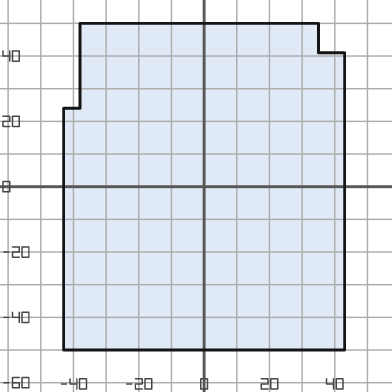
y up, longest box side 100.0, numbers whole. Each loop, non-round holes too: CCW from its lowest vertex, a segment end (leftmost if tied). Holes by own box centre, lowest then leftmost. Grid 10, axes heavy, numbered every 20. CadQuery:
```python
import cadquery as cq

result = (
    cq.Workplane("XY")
    .moveTo(-43.0, -50.0)
    .lineTo(43.0, -50.0)
    .lineTo(43.0, 41.0)
    .lineTo(35.0, 41.0)
    .lineTo(35.0, 50.0)
    .lineTo(-38.0, 50.0)
    .lineTo(-38.0, 24.0)
    .lineTo(-43.0, 24.0)
    .close()
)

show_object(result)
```